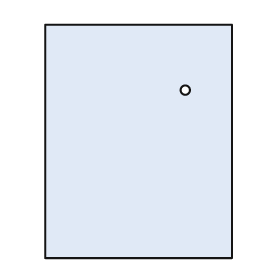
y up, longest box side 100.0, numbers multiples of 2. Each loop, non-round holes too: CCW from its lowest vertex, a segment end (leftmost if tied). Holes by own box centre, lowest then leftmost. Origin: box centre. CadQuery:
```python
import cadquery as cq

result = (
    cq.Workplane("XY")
    .moveTo(-40.0, -50.0)
    .lineTo(40.0, -50.0)
    .lineTo(40.0, 50.0)
    .lineTo(-40.0, 50.0)
    .close()
    .moveTo(20.0, 22.0)
    .circle(2.0)
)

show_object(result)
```